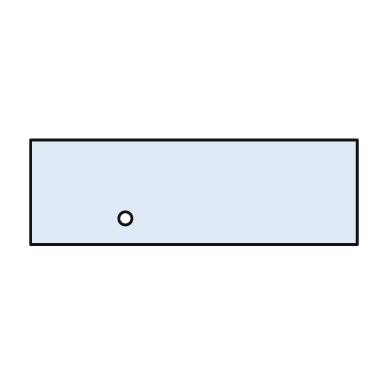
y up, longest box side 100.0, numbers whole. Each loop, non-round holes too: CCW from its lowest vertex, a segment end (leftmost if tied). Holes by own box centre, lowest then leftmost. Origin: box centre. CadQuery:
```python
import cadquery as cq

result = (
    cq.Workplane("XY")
    .moveTo(-50.0, -16.0)
    .lineTo(50.0, -16.0)
    .lineTo(50.0, 16.0)
    .lineTo(-50.0, 16.0)
    .close()
    .moveTo(-21.0, -8.0)
    .circle(2.0)
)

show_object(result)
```